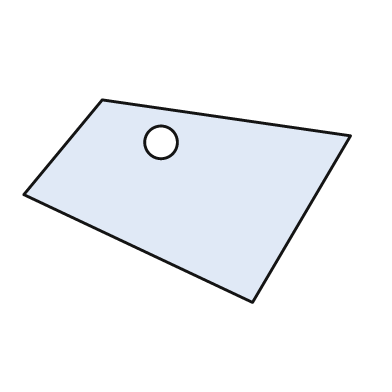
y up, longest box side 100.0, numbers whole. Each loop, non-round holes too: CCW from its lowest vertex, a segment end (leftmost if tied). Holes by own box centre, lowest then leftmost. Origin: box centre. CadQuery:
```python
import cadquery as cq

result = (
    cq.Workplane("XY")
    .moveTo(20.0, -31.0)
    .lineTo(50.0, 20.0)
    .lineTo(-26.0, 31.0)
    .lineTo(-50.0, 2.0)
    .close()
    .moveTo(-8.0, 18.0)
    .circle(5.0)
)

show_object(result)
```